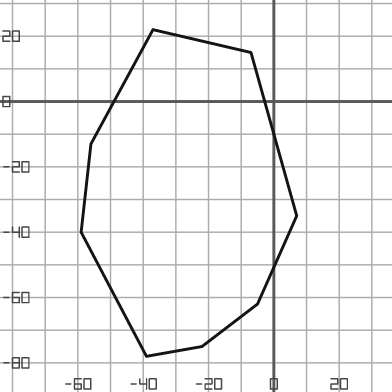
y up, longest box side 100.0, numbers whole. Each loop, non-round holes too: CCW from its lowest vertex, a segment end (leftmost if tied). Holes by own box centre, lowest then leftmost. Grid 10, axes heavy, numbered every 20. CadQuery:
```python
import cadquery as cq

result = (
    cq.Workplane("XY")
    .moveTo(-39.0, -78.0)
    .lineTo(-22.0, -75.0)
    .lineTo(-5.0, -62.0)
    .lineTo(7.0, -35.0)
    .lineTo(-7.0, 15.0)
    .lineTo(-37.0, 22.0)
    .lineTo(-56.0, -13.0)
    .lineTo(-59.0, -40.0)
    .close()
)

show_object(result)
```